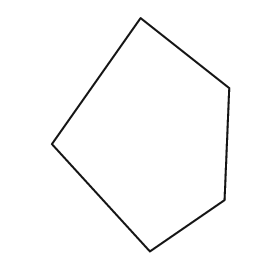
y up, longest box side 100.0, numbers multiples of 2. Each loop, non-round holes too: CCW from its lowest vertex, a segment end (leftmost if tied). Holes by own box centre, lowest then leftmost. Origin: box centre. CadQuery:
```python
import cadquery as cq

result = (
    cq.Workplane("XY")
    .moveTo(4.0, -50.0)
    .lineTo(36.0, -28.0)
    .lineTo(38.0, 20.0)
    .lineTo(0.0, 50.0)
    .lineTo(-38.0, -4.0)
    .close()
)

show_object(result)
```